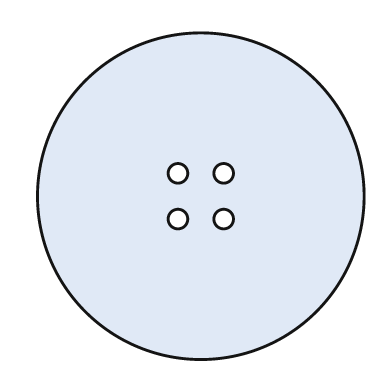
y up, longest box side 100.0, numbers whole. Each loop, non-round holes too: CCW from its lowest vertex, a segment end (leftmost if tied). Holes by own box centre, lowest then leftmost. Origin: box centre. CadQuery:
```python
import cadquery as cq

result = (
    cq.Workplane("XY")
    .moveTo(0.0, 0.0)
    .circle(50.0)
    .moveTo(-7.0, -7.0)
    .circle(3.0)
    .moveTo(7.0, -7.0)
    .circle(3.0)
    .moveTo(-7.0, 7.0)
    .circle(3.0)
    .moveTo(7.0, 7.0)
    .circle(3.0)
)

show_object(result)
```